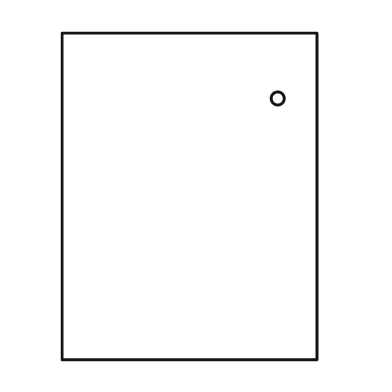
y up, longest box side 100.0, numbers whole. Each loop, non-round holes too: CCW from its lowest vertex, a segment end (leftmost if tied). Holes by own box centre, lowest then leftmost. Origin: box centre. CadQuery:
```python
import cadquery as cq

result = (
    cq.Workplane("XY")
    .moveTo(-39.0, -50.0)
    .lineTo(39.0, -50.0)
    .lineTo(39.0, 50.0)
    .lineTo(-39.0, 50.0)
    .close()
    .moveTo(27.0, 30.0)
    .circle(2.0)
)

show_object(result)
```